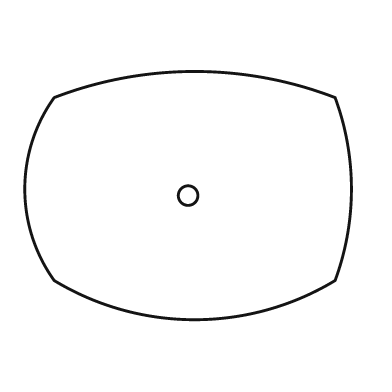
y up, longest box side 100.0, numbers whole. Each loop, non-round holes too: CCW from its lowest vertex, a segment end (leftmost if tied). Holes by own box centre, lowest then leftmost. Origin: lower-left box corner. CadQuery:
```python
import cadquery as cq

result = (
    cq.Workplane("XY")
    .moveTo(9.0, 12.0)
    .threePointArc((52.0, 0.0), (95.0, 12.0))
    .threePointArc((100.0, 40.0), (95.0, 68.0))
    .threePointArc((52.0, 76.0), (9.0, 68.0))
    .threePointArc((0.0, 40.0), (9.0, 12.0))
    .close()
    .moveTo(50.0, 38.0)
    .circle(3.0)
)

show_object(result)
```